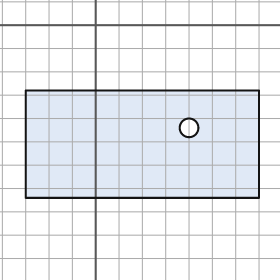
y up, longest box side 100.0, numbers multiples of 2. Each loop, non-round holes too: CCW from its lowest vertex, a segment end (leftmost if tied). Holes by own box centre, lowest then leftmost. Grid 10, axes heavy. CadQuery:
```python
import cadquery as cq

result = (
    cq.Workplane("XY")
    .moveTo(-30.0, -74.0)
    .lineTo(70.0, -74.0)
    .lineTo(70.0, -28.0)
    .lineTo(-30.0, -28.0)
    .close()
    .moveTo(40.0, -44.0)
    .circle(4.0)
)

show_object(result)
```